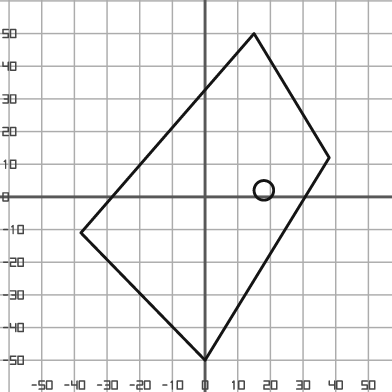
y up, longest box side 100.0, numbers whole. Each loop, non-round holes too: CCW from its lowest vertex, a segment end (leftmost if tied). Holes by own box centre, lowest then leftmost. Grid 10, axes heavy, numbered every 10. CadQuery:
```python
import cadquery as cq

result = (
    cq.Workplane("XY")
    .moveTo(0.0, -50.0)
    .lineTo(38.0, 12.0)
    .lineTo(15.0, 50.0)
    .lineTo(-38.0, -11.0)
    .close()
    .moveTo(18.0, 2.0)
    .circle(3.0)
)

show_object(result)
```